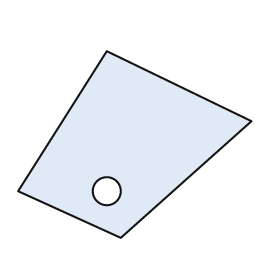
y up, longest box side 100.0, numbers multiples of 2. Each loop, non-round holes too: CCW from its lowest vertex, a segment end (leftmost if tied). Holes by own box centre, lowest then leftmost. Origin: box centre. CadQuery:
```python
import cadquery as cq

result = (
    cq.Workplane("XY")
    .moveTo(-6.0, -40.0)
    .lineTo(50.0, 10.0)
    .lineTo(-12.0, 40.0)
    .lineTo(-50.0, -20.0)
    .close()
    .moveTo(-12.0, -20.0)
    .circle(6.0)
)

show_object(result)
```